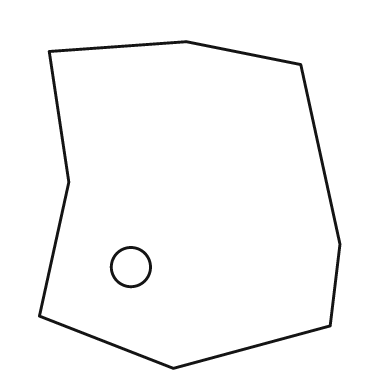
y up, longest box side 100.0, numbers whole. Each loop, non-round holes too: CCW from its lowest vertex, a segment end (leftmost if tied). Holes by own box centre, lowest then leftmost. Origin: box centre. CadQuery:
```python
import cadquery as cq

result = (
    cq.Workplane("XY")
    .moveTo(-5.0, -50.0)
    .lineTo(43.0, -37.0)
    .lineTo(46.0, -12.0)
    .lineTo(34.0, 43.0)
    .lineTo(-1.0, 50.0)
    .lineTo(-43.0, 47.0)
    .lineTo(-37.0, 7.0)
    .lineTo(-46.0, -34.0)
    .close()
    .moveTo(-18.0, -19.0)
    .circle(6.0)
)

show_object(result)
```